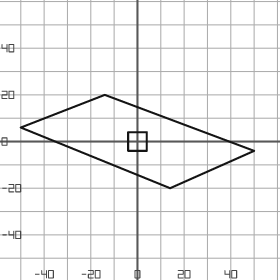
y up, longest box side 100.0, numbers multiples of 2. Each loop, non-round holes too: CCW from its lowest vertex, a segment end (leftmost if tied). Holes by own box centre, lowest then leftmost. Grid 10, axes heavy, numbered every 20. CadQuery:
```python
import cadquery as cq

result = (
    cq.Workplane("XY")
    .moveTo(14.0, -20.0)
    .lineTo(50.0, -4.0)
    .lineTo(-14.0, 20.0)
    .lineTo(-50.0, 6.0)
    .close()
    .moveTo(-4.0, -4.0)
    .lineTo(4.0, -4.0)
    .lineTo(4.0, 4.0)
    .lineTo(-4.0, 4.0)
    .close()
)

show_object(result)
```